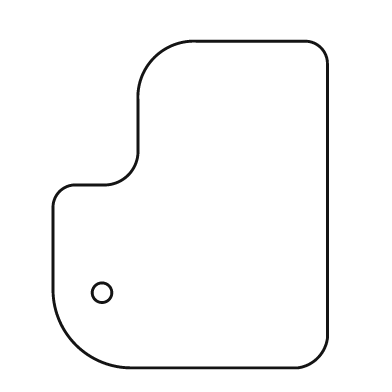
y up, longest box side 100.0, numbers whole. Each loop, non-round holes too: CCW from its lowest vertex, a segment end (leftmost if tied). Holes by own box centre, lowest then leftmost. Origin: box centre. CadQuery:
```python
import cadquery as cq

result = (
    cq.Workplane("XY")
    .moveTo(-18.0, -50.0)
    .lineTo(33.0, -50.0)
    .threePointArc((39.0, -47.0), (42.0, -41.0))
    .lineTo(42.0, 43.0)
    .threePointArc((40.0, 48.0), (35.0, 50.0))
    .lineTo(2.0, 50.0)
    .threePointArc((-11.0, 45.0), (-16.0, 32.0))
    .lineTo(-16.0, 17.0)
    .threePointArc((-19.0, 9.0), (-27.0, 6.0))
    .lineTo(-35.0, 6.0)
    .threePointArc((-40.0, 4.0), (-42.0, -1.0))
    .lineTo(-42.0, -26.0)
    .threePointArc((-35.0, -43.0), (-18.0, -50.0))
    .close()
    .moveTo(-27.0, -27.0)
    .circle(3.0)
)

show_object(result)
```